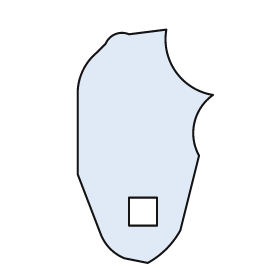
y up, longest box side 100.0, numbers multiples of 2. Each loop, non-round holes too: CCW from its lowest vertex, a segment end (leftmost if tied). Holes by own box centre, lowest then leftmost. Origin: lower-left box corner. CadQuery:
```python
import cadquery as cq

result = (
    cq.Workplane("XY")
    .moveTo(30.0, 0.0)
    .threePointArc((38.0, 6.0), (44.0, 14.0))
    .lineTo(52.0, 46.0)
    .threePointArc((50.0, 60.0), (58.0, 72.0))
    .threePointArc((42.0, 82.0), (38.0, 100.0))
    .lineTo(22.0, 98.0)
    .threePointArc((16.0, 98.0), (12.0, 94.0))
    .lineTo(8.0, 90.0)
    .threePointArc((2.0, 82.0), (0.0, 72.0))
    .lineTo(0.0, 38.0)
    .lineTo(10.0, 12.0)
    .threePointArc((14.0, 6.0), (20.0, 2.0))
    .close()
    .moveTo(22.0, 16.0)
    .lineTo(34.0, 16.0)
    .lineTo(34.0, 28.0)
    .lineTo(22.0, 28.0)
    .close()
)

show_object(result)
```